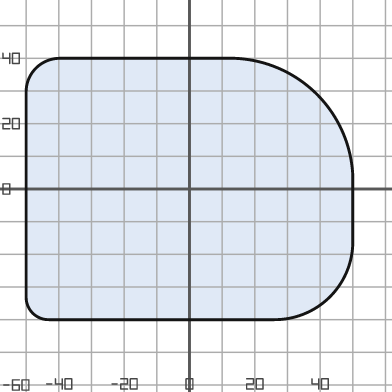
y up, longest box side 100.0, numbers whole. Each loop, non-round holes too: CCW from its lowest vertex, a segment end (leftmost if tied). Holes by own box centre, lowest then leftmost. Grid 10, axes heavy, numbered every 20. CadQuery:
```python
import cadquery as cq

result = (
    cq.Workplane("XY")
    .moveTo(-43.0, -40.0)
    .lineTo(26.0, -40.0)
    .threePointArc((43.0, -33.0), (50.0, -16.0))
    .lineTo(50.0, 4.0)
    .threePointArc((39.0, 29.0), (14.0, 40.0))
    .lineTo(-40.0, 40.0)
    .threePointArc((-47.0, 37.0), (-50.0, 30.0))
    .lineTo(-50.0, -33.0)
    .threePointArc((-48.0, -38.0), (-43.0, -40.0))
    .close()
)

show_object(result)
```